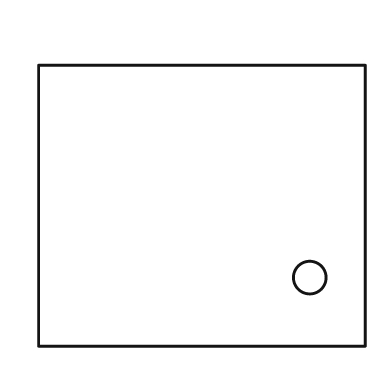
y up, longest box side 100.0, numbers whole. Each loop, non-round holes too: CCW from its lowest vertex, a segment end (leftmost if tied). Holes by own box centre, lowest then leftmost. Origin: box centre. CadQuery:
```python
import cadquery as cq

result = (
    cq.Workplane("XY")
    .moveTo(-50.0, -43.0)
    .lineTo(50.0, -43.0)
    .lineTo(50.0, 43.0)
    .lineTo(-50.0, 43.0)
    .close()
    .moveTo(33.0, -22.0)
    .circle(5.0)
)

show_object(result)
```